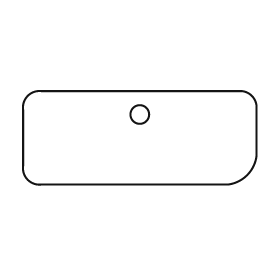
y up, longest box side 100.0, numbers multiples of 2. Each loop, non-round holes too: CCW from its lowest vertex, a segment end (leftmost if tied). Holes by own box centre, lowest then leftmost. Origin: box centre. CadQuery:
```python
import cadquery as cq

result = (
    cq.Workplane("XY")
    .moveTo(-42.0, -20.0)
    .lineTo(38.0, -20.0)
    .threePointArc((46.0, -16.0), (50.0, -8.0))
    .lineTo(50.0, 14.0)
    .threePointArc((48.0, 18.0), (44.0, 20.0))
    .lineTo(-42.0, 20.0)
    .threePointArc((-48.0, 18.0), (-50.0, 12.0))
    .lineTo(-50.0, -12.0)
    .threePointArc((-48.0, -18.0), (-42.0, -20.0))
    .close()
    .moveTo(0.0, 10.0)
    .circle(4.0)
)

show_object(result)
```